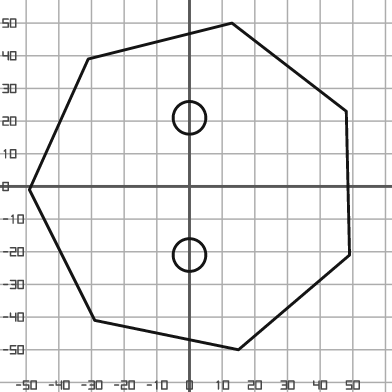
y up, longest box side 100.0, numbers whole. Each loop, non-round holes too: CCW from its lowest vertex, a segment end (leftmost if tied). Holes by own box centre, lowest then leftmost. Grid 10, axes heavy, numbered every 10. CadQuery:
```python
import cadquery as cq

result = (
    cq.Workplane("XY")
    .moveTo(15.0, -50.0)
    .lineTo(49.0, -21.0)
    .lineTo(48.0, 23.0)
    .lineTo(13.0, 50.0)
    .lineTo(-31.0, 39.0)
    .lineTo(-49.0, -1.0)
    .lineTo(-29.0, -41.0)
    .close()
    .moveTo(0.0, -21.0)
    .circle(5.0)
    .moveTo(0.0, 21.0)
    .circle(5.0)
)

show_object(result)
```